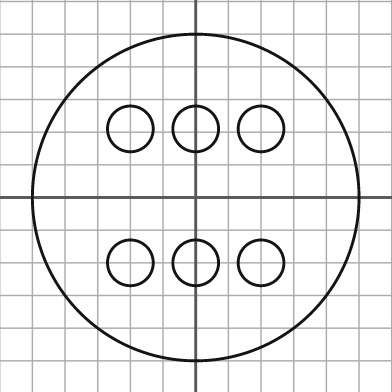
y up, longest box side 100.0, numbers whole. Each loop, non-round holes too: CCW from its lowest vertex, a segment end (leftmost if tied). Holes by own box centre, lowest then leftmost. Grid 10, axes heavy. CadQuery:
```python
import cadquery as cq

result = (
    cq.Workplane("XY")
    .moveTo(0.0, 0.0)
    .circle(50.0)
    .moveTo(-20.0, -20.0)
    .circle(7.0)
    .moveTo(0.0, -20.0)
    .circle(7.0)
    .moveTo(20.0, -20.0)
    .circle(7.0)
    .moveTo(-20.0, 21.0)
    .circle(7.0)
    .moveTo(0.0, 21.0)
    .circle(7.0)
    .moveTo(20.0, 21.0)
    .circle(7.0)
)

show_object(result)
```